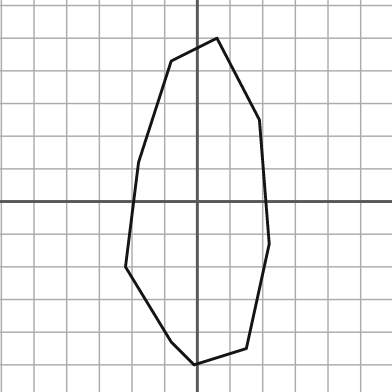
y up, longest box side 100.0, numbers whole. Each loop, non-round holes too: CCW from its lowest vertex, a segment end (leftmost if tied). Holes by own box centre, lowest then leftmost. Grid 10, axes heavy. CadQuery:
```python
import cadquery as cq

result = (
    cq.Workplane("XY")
    .moveTo(-1.0, -50.0)
    .lineTo(15.0, -45.0)
    .lineTo(22.0, -13.0)
    .lineTo(19.0, 25.0)
    .lineTo(6.0, 50.0)
    .lineTo(-8.0, 43.0)
    .lineTo(-18.0, 12.0)
    .lineTo(-22.0, -20.0)
    .lineTo(-8.0, -43.0)
    .close()
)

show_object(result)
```